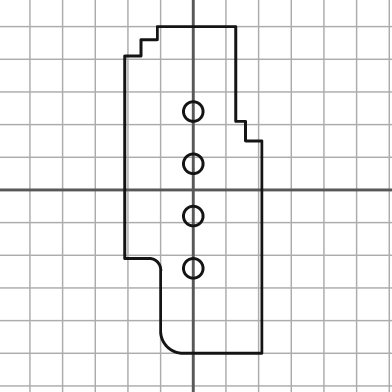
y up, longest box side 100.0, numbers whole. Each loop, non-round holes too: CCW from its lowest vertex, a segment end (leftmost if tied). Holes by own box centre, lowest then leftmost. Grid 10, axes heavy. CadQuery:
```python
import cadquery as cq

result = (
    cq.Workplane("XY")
    .moveTo(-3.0, -50.0)
    .lineTo(21.0, -50.0)
    .lineTo(21.0, 15.0)
    .lineTo(16.0, 15.0)
    .lineTo(16.0, 21.0)
    .lineTo(13.0, 21.0)
    .lineTo(13.0, 50.0)
    .lineTo(-11.0, 50.0)
    .lineTo(-11.0, 46.0)
    .lineTo(-16.0, 46.0)
    .lineTo(-16.0, 41.0)
    .lineTo(-21.0, 41.0)
    .lineTo(-21.0, -21.0)
    .lineTo(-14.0, -21.0)
    .threePointArc((-11.0, -22.0), (-10.0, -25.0))
    .lineTo(-10.0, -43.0)
    .threePointArc((-8.0, -48.0), (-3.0, -50.0))
    .close()
    .moveTo(0.0, -24.0)
    .circle(3.0)
    .moveTo(0.0, -8.0)
    .circle(3.0)
    .moveTo(0.0, 8.0)
    .circle(3.0)
    .moveTo(0.0, 24.0)
    .circle(3.0)
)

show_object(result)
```